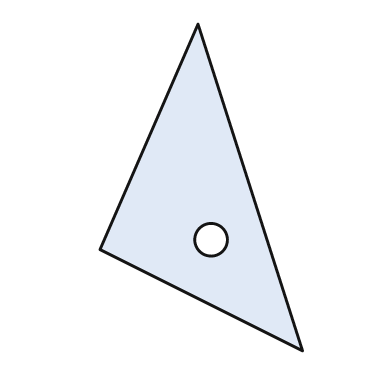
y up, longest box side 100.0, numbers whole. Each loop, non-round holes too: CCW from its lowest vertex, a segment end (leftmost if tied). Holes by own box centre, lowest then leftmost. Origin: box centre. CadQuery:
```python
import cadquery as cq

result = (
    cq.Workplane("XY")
    .moveTo(31.0, -50.0)
    .lineTo(-1.0, 50.0)
    .lineTo(-31.0, -19.0)
    .close()
    .moveTo(3.0, -16.0)
    .circle(5.0)
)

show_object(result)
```